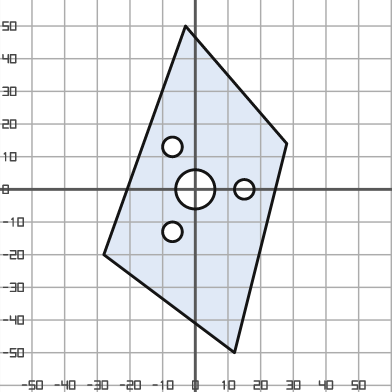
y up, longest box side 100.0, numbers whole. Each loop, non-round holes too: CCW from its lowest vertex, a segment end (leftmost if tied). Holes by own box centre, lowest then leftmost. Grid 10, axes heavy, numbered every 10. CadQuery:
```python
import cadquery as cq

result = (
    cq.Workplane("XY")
    .moveTo(12.0, -50.0)
    .lineTo(28.0, 14.0)
    .lineTo(-3.0, 50.0)
    .lineTo(-28.0, -20.0)
    .close()
    .moveTo(-7.0, -13.0)
    .circle(3.0)
    .moveTo(0.0, 0.0)
    .circle(6.0)
    .moveTo(15.0, 0.0)
    .circle(3.0)
    .moveTo(-7.0, 13.0)
    .circle(3.0)
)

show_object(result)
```